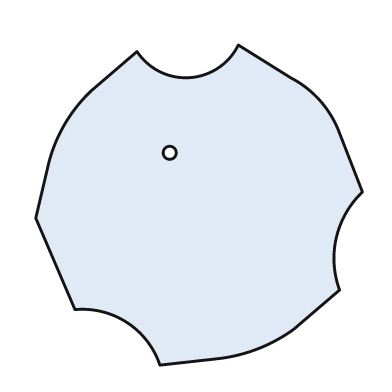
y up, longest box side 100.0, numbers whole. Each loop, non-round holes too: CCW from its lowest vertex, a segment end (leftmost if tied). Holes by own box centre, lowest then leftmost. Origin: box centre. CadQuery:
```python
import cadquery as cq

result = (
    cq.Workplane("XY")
    .moveTo(-12.0, -49.0)
    .lineTo(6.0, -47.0)
    .threePointArc((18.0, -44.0), (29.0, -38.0))
    .lineTo(43.0, -26.0)
    .threePointArc((42.0, -10.0), (50.0, 4.0))
    .lineTo(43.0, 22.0)
    .threePointArc((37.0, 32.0), (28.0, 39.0))
    .lineTo(12.0, 49.0)
    .threePointArc((-3.0, 39.0), (-19.0, 47.0))
    .lineTo(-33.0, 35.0)
    .threePointArc((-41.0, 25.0), (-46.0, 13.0))
    .lineTo(-50.0, -4.0)
    .lineTo(-38.0, -32.0)
    .threePointArc((-22.0, -36.0), (-12.0, -49.0))
    .close()
    .moveTo(-9.0, 16.0)
    .circle(2.0)
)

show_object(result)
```